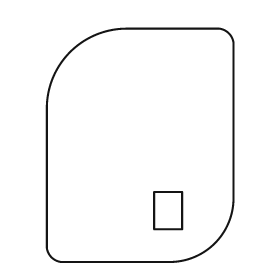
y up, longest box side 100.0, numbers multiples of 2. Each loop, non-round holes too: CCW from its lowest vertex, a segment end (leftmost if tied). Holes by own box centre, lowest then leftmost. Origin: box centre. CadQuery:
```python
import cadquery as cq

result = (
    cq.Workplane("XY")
    .moveTo(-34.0, -50.0)
    .lineTo(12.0, -50.0)
    .threePointArc((32.0, -42.0), (40.0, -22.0))
    .lineTo(40.0, 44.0)
    .threePointArc((38.0, 48.0), (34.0, 50.0))
    .lineTo(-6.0, 50.0)
    .threePointArc((-30.0, 40.0), (-40.0, 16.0))
    .lineTo(-40.0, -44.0)
    .threePointArc((-38.0, -48.0), (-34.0, -50.0))
    .close()
    .moveTo(6.0, -36.0)
    .lineTo(18.0, -36.0)
    .lineTo(18.0, -20.0)
    .lineTo(6.0, -20.0)
    .close()
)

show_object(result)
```